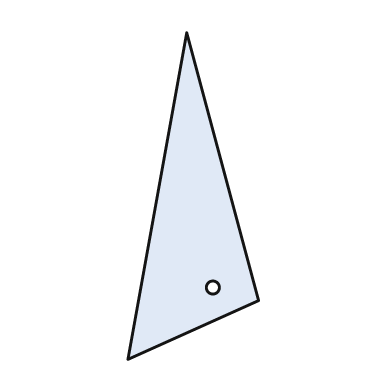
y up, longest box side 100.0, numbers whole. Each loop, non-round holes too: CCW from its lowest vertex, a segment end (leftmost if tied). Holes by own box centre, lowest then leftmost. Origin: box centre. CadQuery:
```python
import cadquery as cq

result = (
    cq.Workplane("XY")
    .moveTo(-20.0, -50.0)
    .lineTo(20.0, -32.0)
    .lineTo(-2.0, 50.0)
    .close()
    .moveTo(6.0, -28.0)
    .circle(2.0)
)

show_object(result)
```